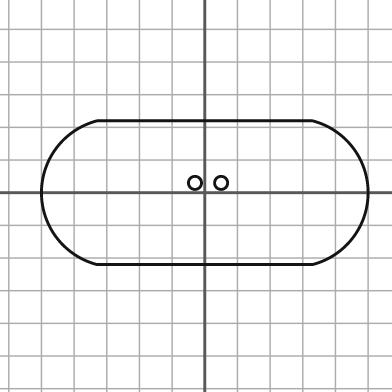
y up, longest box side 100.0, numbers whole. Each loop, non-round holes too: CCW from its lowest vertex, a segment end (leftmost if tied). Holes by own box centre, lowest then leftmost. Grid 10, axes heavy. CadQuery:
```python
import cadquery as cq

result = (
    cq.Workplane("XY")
    .moveTo(-33.0, -22.0)
    .lineTo(33.0, -22.0)
    .threePointArc((50.0, 0.0), (33.0, 22.0))
    .lineTo(-33.0, 22.0)
    .threePointArc((-50.0, 0.0), (-33.0, -22.0))
    .close()
    .moveTo(-3.0, 3.0)
    .circle(2.0)
    .moveTo(5.0, 3.0)
    .circle(2.0)
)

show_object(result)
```